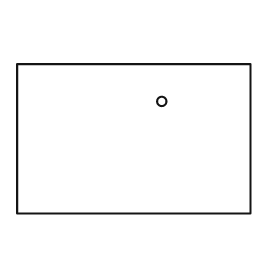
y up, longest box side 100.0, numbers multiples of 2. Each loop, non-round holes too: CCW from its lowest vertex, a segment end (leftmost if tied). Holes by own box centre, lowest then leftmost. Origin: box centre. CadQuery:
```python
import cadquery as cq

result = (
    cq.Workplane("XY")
    .moveTo(-50.0, -32.0)
    .lineTo(50.0, -32.0)
    .lineTo(50.0, 32.0)
    .lineTo(-50.0, 32.0)
    .close()
    .moveTo(12.0, 16.0)
    .circle(2.0)
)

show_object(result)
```